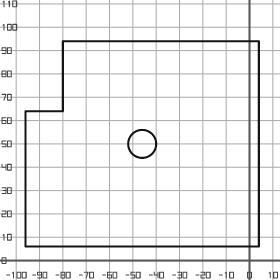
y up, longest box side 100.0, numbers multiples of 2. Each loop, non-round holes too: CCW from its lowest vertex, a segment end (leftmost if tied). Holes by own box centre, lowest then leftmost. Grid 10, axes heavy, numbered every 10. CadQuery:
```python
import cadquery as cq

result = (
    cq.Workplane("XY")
    .moveTo(-96.0, 6.0)
    .lineTo(4.0, 6.0)
    .lineTo(4.0, 94.0)
    .lineTo(-80.0, 94.0)
    .lineTo(-80.0, 64.0)
    .lineTo(-96.0, 64.0)
    .close()
    .moveTo(-46.0, 50.0)
    .circle(6.0)
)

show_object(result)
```